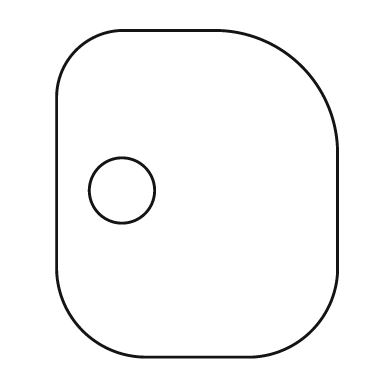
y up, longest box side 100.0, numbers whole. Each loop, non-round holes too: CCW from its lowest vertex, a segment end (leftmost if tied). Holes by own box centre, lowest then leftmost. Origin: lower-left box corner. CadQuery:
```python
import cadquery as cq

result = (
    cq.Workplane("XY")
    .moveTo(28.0, 0.0)
    .lineTo(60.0, 0.0)
    .threePointArc((78.0, 8.0), (86.0, 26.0))
    .lineTo(86.0, 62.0)
    .threePointArc((75.0, 89.0), (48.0, 100.0))
    .lineTo(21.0, 100.0)
    .threePointArc((6.0, 94.0), (0.0, 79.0))
    .lineTo(0.0, 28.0)
    .threePointArc((8.0, 8.0), (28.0, 0.0))
    .close()
    .moveTo(20.0, 51.0)
    .circle(10.0)
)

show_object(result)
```